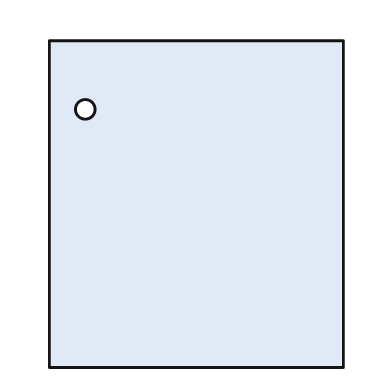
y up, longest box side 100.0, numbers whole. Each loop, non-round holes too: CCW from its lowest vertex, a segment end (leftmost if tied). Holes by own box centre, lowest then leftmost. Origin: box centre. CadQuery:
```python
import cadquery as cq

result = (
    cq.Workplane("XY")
    .moveTo(-45.0, -50.0)
    .lineTo(45.0, -50.0)
    .lineTo(45.0, 50.0)
    .lineTo(-45.0, 50.0)
    .close()
    .moveTo(-34.0, 29.0)
    .circle(3.0)
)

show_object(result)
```